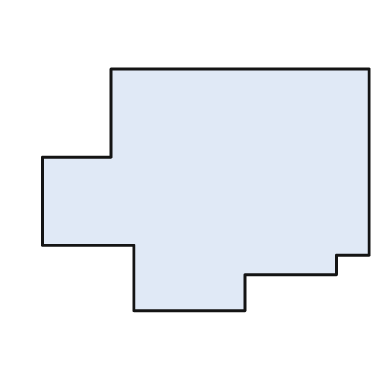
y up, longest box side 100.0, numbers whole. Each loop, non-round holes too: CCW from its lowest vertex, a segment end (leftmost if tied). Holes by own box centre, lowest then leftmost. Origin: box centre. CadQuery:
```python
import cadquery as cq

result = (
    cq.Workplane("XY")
    .moveTo(-22.0, -37.0)
    .lineTo(12.0, -37.0)
    .lineTo(12.0, -26.0)
    .lineTo(40.0, -26.0)
    .lineTo(40.0, -20.0)
    .lineTo(50.0, -20.0)
    .lineTo(50.0, 37.0)
    .lineTo(-29.0, 37.0)
    .lineTo(-29.0, 10.0)
    .lineTo(-50.0, 10.0)
    .lineTo(-50.0, -17.0)
    .lineTo(-22.0, -17.0)
    .close()
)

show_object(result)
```